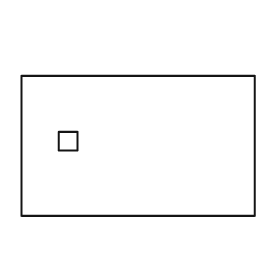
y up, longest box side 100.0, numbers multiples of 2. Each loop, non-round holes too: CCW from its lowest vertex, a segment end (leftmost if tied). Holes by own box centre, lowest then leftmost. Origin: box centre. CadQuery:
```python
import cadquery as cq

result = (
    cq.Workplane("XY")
    .moveTo(-50.0, -30.0)
    .lineTo(50.0, -30.0)
    .lineTo(50.0, 30.0)
    .lineTo(-50.0, 30.0)
    .close()
    .moveTo(-34.0, -2.0)
    .lineTo(-26.0, -2.0)
    .lineTo(-26.0, 6.0)
    .lineTo(-34.0, 6.0)
    .close()
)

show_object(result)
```